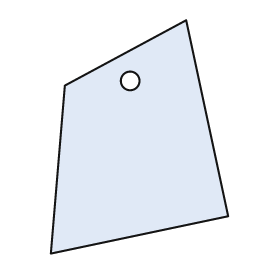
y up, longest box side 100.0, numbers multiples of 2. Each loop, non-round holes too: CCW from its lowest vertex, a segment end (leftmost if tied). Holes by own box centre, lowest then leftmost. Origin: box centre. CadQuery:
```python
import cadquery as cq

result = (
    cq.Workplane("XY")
    .moveTo(-38.0, -50.0)
    .lineTo(38.0, -34.0)
    .lineTo(20.0, 50.0)
    .lineTo(-32.0, 22.0)
    .close()
    .moveTo(-4.0, 24.0)
    .circle(4.0)
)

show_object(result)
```